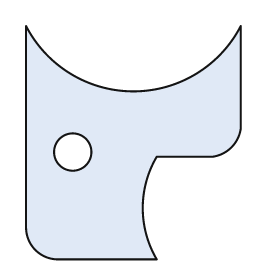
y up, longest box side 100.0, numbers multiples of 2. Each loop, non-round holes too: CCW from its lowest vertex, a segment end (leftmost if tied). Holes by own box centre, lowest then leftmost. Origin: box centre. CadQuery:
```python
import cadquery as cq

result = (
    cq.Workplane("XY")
    .moveTo(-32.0, -50.0)
    .lineTo(10.0, -50.0)
    .threePointArc((4.0, -28.0), (10.0, -6.0))
    .lineTo(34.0, -6.0)
    .threePointArc((42.0, -2.0), (46.0, 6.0))
    .lineTo(46.0, 50.0)
    .threePointArc((0.0, 22.0), (-46.0, 50.0))
    .lineTo(-46.0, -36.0)
    .threePointArc((-42.0, -46.0), (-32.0, -50.0))
    .close()
    .moveTo(-26.0, -4.0)
    .circle(8.0)
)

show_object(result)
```